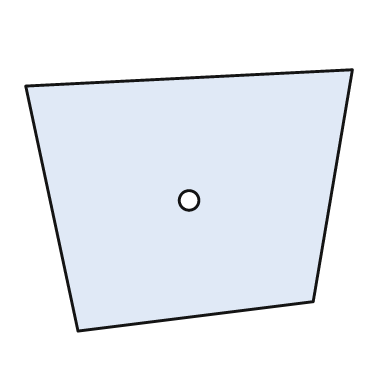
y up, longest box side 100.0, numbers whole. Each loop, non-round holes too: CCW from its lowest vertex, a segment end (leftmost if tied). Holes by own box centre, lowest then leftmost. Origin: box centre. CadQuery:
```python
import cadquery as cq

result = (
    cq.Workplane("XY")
    .moveTo(-34.0, -40.0)
    .lineTo(38.0, -31.0)
    .lineTo(50.0, 40.0)
    .lineTo(-50.0, 35.0)
    .close()
    .moveTo(0.0, 0.0)
    .circle(3.0)
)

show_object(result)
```